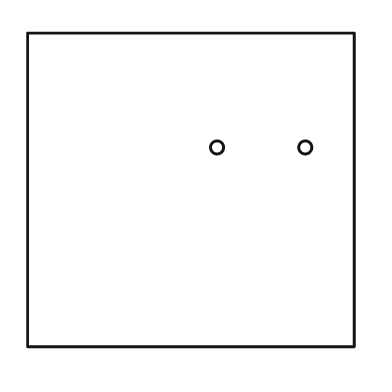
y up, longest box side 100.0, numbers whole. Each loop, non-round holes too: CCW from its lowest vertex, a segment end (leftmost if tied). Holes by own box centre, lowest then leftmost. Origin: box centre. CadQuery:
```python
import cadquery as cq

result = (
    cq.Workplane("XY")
    .moveTo(-50.0, -48.0)
    .lineTo(50.0, -48.0)
    .lineTo(50.0, 48.0)
    .lineTo(-50.0, 48.0)
    .close()
    .moveTo(8.0, 13.0)
    .circle(2.0)
    .moveTo(35.0, 13.0)
    .circle(2.0)
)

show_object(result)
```